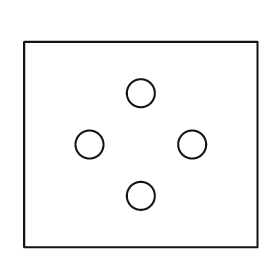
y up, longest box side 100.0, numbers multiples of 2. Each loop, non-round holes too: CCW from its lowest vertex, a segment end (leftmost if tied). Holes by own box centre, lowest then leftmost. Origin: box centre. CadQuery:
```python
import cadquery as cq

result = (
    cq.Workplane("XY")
    .moveTo(-50.0, -44.0)
    .lineTo(50.0, -44.0)
    .lineTo(50.0, 44.0)
    .lineTo(-50.0, 44.0)
    .close()
    .moveTo(0.0, -22.0)
    .circle(6.0)
    .moveTo(-22.0, 0.0)
    .circle(6.0)
    .moveTo(22.0, 0.0)
    .circle(6.0)
    .moveTo(0.0, 22.0)
    .circle(6.0)
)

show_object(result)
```